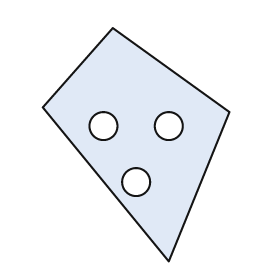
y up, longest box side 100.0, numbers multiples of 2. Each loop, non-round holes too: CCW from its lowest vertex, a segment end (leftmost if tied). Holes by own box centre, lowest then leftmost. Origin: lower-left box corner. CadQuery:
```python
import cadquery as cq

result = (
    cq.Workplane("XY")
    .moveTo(54.0, 0.0)
    .lineTo(80.0, 64.0)
    .lineTo(30.0, 100.0)
    .lineTo(0.0, 66.0)
    .close()
    .moveTo(40.0, 34.0)
    .circle(6.0)
    .moveTo(26.0, 58.0)
    .circle(6.0)
    .moveTo(54.0, 58.0)
    .circle(6.0)
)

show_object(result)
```